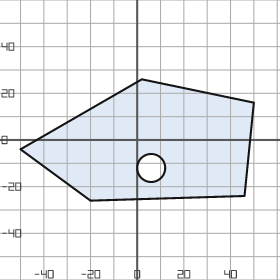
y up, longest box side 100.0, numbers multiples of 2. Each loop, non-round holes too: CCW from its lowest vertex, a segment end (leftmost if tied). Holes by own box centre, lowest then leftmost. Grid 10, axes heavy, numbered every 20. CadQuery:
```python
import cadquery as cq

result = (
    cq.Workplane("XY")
    .moveTo(-20.0, -26.0)
    .lineTo(46.0, -24.0)
    .lineTo(50.0, 16.0)
    .lineTo(2.0, 26.0)
    .lineTo(-50.0, -4.0)
    .close()
    .moveTo(6.0, -12.0)
    .circle(6.0)
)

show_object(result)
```